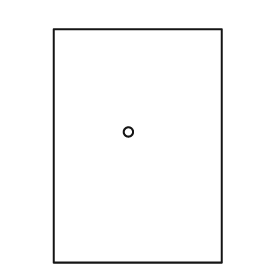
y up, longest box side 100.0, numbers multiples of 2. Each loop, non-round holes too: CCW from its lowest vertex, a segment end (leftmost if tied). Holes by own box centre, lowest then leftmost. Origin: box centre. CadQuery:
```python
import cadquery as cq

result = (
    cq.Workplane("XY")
    .moveTo(-36.0, -50.0)
    .lineTo(36.0, -50.0)
    .lineTo(36.0, 50.0)
    .lineTo(-36.0, 50.0)
    .close()
    .moveTo(-4.0, 6.0)
    .circle(2.0)
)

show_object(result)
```